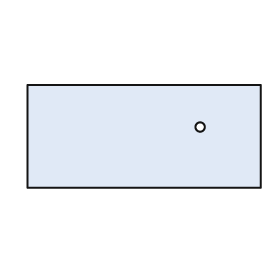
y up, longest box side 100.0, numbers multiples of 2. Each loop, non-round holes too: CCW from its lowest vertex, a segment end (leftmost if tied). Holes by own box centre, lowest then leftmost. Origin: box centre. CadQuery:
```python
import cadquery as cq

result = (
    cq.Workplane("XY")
    .moveTo(-50.0, -22.0)
    .lineTo(50.0, -22.0)
    .lineTo(50.0, 22.0)
    .lineTo(-50.0, 22.0)
    .close()
    .moveTo(24.0, 4.0)
    .circle(2.0)
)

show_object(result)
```